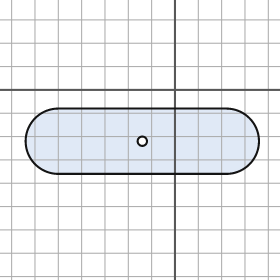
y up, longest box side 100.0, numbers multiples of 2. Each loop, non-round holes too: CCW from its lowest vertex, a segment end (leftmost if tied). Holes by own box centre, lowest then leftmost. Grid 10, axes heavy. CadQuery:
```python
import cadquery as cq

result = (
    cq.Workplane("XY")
    .moveTo(-50.0, -36.0)
    .lineTo(22.0, -36.0)
    .threePointArc((36.0, -22.0), (22.0, -8.0))
    .lineTo(-50.0, -8.0)
    .threePointArc((-64.0, -22.0), (-50.0, -36.0))
    .close()
    .moveTo(-14.0, -22.0)
    .circle(2.0)
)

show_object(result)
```